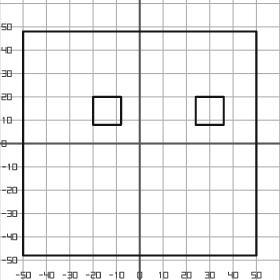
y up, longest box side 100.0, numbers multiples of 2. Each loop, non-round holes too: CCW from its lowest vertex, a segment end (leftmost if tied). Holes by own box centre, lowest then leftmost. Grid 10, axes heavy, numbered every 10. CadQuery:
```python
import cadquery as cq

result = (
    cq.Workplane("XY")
    .moveTo(-50.0, -48.0)
    .lineTo(50.0, -48.0)
    .lineTo(50.0, 48.0)
    .lineTo(-50.0, 48.0)
    .close()
    .moveTo(-20.0, 8.0)
    .lineTo(-8.0, 8.0)
    .lineTo(-8.0, 20.0)
    .lineTo(-20.0, 20.0)
    .close()
    .moveTo(24.0, 8.0)
    .lineTo(36.0, 8.0)
    .lineTo(36.0, 20.0)
    .lineTo(24.0, 20.0)
    .close()
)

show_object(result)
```